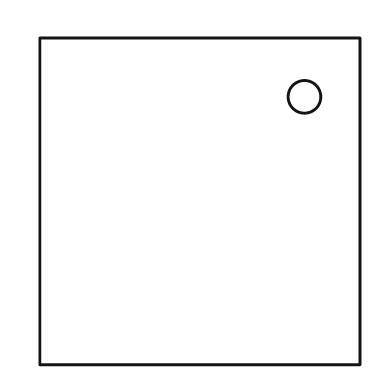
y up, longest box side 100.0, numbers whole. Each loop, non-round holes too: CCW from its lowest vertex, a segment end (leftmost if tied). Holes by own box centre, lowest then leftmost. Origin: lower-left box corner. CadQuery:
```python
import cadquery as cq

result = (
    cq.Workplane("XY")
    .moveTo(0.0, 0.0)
    .lineTo(98.0, 0.0)
    .lineTo(98.0, 100.0)
    .lineTo(0.0, 100.0)
    .close()
    .moveTo(81.0, 82.0)
    .circle(5.0)
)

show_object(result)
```